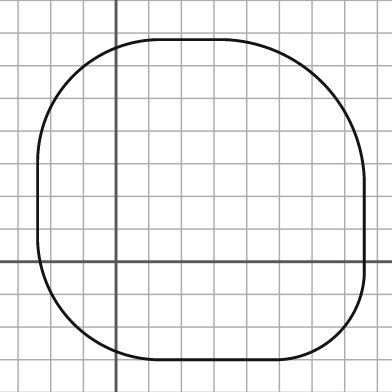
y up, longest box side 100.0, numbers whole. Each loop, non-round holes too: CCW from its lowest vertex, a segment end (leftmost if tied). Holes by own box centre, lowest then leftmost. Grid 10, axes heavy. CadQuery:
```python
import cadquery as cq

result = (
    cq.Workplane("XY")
    .moveTo(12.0, -30.0)
    .lineTo(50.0, -30.0)
    .threePointArc((68.0, -22.0), (76.0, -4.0))
    .lineTo(76.0, 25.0)
    .threePointArc((63.0, 55.0), (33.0, 68.0))
    .lineTo(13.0, 68.0)
    .threePointArc((-13.0, 57.0), (-24.0, 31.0))
    .lineTo(-24.0, 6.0)
    .threePointArc((-13.0, -19.0), (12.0, -30.0))
    .close()
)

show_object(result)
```